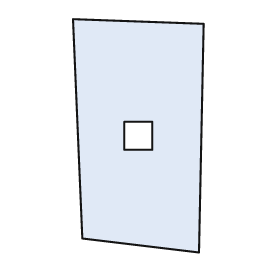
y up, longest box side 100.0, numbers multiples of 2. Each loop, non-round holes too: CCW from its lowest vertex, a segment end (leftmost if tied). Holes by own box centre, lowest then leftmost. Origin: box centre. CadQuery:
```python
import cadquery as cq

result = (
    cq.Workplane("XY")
    .moveTo(26.0, -50.0)
    .lineTo(28.0, 48.0)
    .lineTo(-28.0, 50.0)
    .lineTo(-24.0, -44.0)
    .close()
    .moveTo(-6.0, -6.0)
    .lineTo(6.0, -6.0)
    .lineTo(6.0, 6.0)
    .lineTo(-6.0, 6.0)
    .close()
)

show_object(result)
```